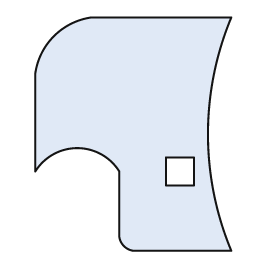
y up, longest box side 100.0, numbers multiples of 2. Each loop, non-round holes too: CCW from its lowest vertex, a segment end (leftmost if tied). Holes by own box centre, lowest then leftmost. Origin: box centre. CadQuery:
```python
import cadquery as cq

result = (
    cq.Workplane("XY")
    .moveTo(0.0, -50.0)
    .lineTo(42.0, -50.0)
    .threePointArc((32.0, 0.0), (42.0, 50.0))
    .lineTo(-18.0, 50.0)
    .threePointArc((-34.0, 42.0), (-42.0, 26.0))
    .lineTo(-42.0, -16.0)
    .threePointArc((-24.0, -6.0), (-6.0, -16.0))
    .lineTo(-6.0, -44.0)
    .threePointArc((-4.0, -48.0), (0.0, -50.0))
    .close()
    .moveTo(14.0, -22.0)
    .lineTo(26.0, -22.0)
    .lineTo(26.0, -10.0)
    .lineTo(14.0, -10.0)
    .close()
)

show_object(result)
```